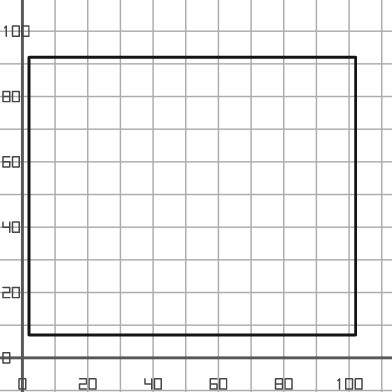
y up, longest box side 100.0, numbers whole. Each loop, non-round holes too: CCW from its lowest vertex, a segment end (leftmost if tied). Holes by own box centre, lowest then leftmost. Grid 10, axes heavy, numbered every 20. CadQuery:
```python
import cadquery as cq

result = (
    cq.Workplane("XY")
    .moveTo(2.0, 7.0)
    .lineTo(102.0, 7.0)
    .lineTo(102.0, 92.0)
    .lineTo(2.0, 92.0)
    .close()
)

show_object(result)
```